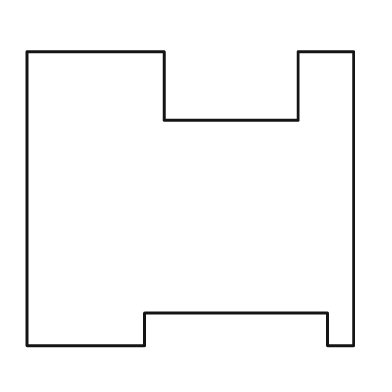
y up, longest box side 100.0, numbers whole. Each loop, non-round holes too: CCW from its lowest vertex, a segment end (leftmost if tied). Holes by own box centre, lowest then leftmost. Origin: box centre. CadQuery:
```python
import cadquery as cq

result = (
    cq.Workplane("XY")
    .moveTo(-50.0, -45.0)
    .lineTo(-14.0, -45.0)
    .lineTo(-14.0, -35.0)
    .lineTo(42.0, -35.0)
    .lineTo(42.0, -45.0)
    .lineTo(50.0, -45.0)
    .lineTo(50.0, 45.0)
    .lineTo(33.0, 45.0)
    .lineTo(33.0, 24.0)
    .lineTo(-8.0, 24.0)
    .lineTo(-8.0, 45.0)
    .lineTo(-50.0, 45.0)
    .close()
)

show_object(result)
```